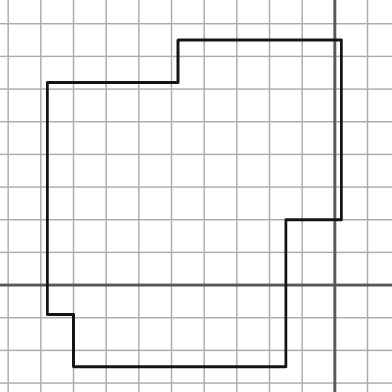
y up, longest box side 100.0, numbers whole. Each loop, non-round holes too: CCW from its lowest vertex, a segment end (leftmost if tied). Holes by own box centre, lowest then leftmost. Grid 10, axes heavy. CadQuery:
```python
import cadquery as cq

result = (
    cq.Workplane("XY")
    .moveTo(-80.0, -25.0)
    .lineTo(-15.0, -25.0)
    .lineTo(-15.0, 20.0)
    .lineTo(2.0, 20.0)
    .lineTo(2.0, 75.0)
    .lineTo(-48.0, 75.0)
    .lineTo(-48.0, 62.0)
    .lineTo(-88.0, 62.0)
    .lineTo(-88.0, -9.0)
    .lineTo(-80.0, -9.0)
    .close()
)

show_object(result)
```